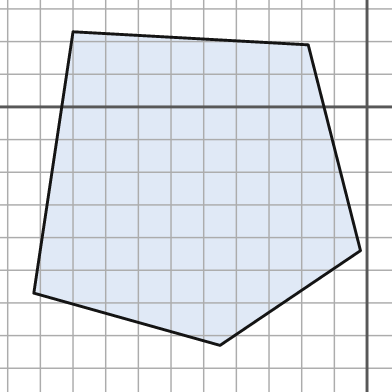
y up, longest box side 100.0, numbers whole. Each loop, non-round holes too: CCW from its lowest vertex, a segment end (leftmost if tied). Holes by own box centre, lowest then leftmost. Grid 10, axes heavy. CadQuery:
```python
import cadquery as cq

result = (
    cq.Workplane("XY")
    .moveTo(-45.0, -73.0)
    .lineTo(-2.0, -44.0)
    .lineTo(-18.0, 19.0)
    .lineTo(-90.0, 23.0)
    .lineTo(-102.0, -57.0)
    .close()
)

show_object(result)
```